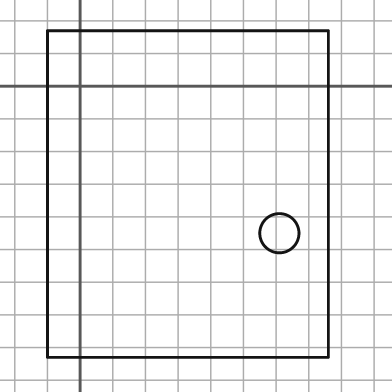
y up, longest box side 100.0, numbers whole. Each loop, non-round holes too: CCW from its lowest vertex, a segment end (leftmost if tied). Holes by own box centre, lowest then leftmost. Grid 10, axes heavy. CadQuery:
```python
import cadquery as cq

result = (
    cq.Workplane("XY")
    .moveTo(-10.0, -83.0)
    .lineTo(76.0, -83.0)
    .lineTo(76.0, 17.0)
    .lineTo(-10.0, 17.0)
    .close()
    .moveTo(61.0, -45.0)
    .circle(6.0)
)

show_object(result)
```